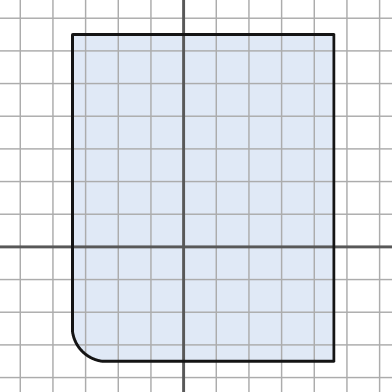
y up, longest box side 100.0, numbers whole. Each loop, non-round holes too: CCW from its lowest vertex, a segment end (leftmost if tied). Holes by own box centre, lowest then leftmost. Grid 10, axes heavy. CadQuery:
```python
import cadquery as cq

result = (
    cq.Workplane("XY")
    .moveTo(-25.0, -35.0)
    .lineTo(46.0, -35.0)
    .lineTo(46.0, 65.0)
    .lineTo(-34.0, 65.0)
    .lineTo(-34.0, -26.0)
    .threePointArc((-31.0, -32.0), (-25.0, -35.0))
    .close()
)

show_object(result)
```